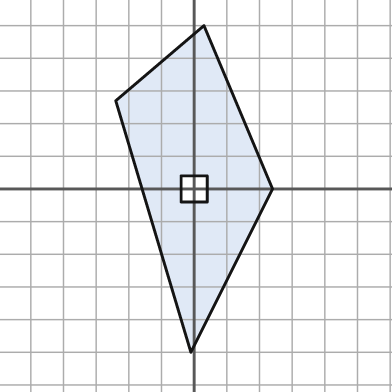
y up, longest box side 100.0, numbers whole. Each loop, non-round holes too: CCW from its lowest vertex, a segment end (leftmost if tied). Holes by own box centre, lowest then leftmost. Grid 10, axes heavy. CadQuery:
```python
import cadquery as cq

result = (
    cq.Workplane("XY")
    .moveTo(-1.0, -50.0)
    .lineTo(24.0, 0.0)
    .lineTo(3.0, 50.0)
    .lineTo(-24.0, 27.0)
    .close()
    .moveTo(-4.0, -4.0)
    .lineTo(4.0, -4.0)
    .lineTo(4.0, 4.0)
    .lineTo(-4.0, 4.0)
    .close()
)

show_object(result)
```